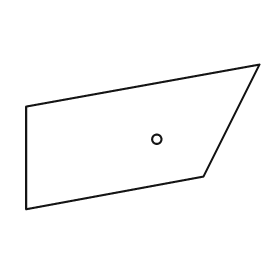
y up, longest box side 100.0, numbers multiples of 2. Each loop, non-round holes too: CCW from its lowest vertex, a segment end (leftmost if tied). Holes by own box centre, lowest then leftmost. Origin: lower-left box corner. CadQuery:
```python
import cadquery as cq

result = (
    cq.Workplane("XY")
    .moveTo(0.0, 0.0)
    .lineTo(76.0, 14.0)
    .lineTo(100.0, 62.0)
    .lineTo(0.0, 44.0)
    .close()
    .moveTo(56.0, 30.0)
    .circle(2.0)
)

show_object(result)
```